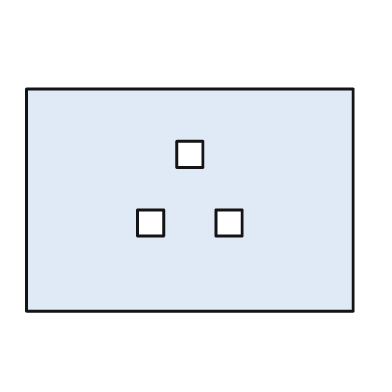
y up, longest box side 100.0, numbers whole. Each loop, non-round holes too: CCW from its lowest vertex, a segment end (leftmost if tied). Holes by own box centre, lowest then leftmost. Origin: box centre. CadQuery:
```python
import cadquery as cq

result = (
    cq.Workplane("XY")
    .moveTo(-50.0, -34.0)
    .lineTo(50.0, -34.0)
    .lineTo(50.0, 34.0)
    .lineTo(-50.0, 34.0)
    .close()
    .moveTo(-16.0, -11.0)
    .lineTo(-8.0, -11.0)
    .lineTo(-8.0, -3.0)
    .lineTo(-16.0, -3.0)
    .close()
    .moveTo(8.0, -11.0)
    .lineTo(16.0, -11.0)
    .lineTo(16.0, -3.0)
    .lineTo(8.0, -3.0)
    .close()
    .moveTo(-4.0, 10.0)
    .lineTo(4.0, 10.0)
    .lineTo(4.0, 18.0)
    .lineTo(-4.0, 18.0)
    .close()
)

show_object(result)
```